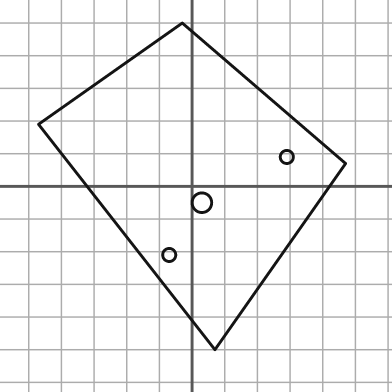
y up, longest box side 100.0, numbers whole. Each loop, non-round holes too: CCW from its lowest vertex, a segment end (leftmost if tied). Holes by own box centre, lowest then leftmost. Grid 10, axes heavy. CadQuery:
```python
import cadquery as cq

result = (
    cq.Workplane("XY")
    .moveTo(7.0, -50.0)
    .lineTo(47.0, 7.0)
    .lineTo(-3.0, 50.0)
    .lineTo(-47.0, 19.0)
    .close()
    .moveTo(-7.0, -21.0)
    .circle(2.0)
    .moveTo(3.0, -5.0)
    .circle(3.0)
    .moveTo(29.0, 9.0)
    .circle(2.0)
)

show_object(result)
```